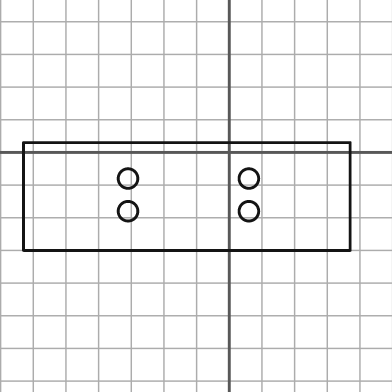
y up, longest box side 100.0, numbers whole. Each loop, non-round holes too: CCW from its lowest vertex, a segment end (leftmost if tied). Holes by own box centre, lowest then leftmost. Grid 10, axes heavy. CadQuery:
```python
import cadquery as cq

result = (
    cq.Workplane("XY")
    .moveTo(-63.0, -30.0)
    .lineTo(37.0, -30.0)
    .lineTo(37.0, 3.0)
    .lineTo(-63.0, 3.0)
    .close()
    .moveTo(-31.0, -18.0)
    .circle(3.0)
    .moveTo(6.0, -18.0)
    .circle(3.0)
    .moveTo(-31.0, -8.0)
    .circle(3.0)
    .moveTo(6.0, -8.0)
    .circle(3.0)
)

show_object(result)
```